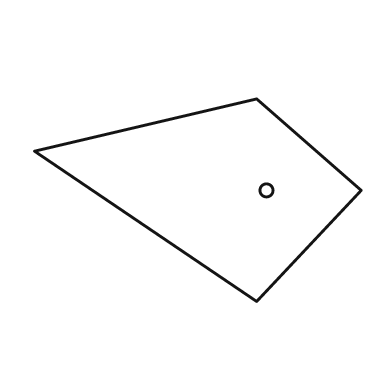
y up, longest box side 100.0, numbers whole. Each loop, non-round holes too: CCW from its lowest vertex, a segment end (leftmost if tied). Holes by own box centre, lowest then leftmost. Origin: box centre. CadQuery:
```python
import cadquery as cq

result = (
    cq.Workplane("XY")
    .moveTo(18.0, -31.0)
    .lineTo(50.0, 3.0)
    .lineTo(18.0, 31.0)
    .lineTo(-50.0, 15.0)
    .close()
    .moveTo(21.0, 3.0)
    .circle(2.0)
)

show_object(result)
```